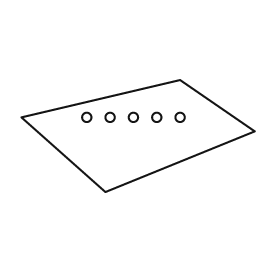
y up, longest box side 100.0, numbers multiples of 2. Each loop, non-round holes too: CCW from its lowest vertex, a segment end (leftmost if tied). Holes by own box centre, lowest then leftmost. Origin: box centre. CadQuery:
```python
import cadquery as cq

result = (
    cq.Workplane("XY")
    .moveTo(-14.0, -24.0)
    .lineTo(50.0, 2.0)
    .lineTo(18.0, 24.0)
    .lineTo(-50.0, 8.0)
    .close()
    .moveTo(-22.0, 8.0)
    .circle(2.0)
    .moveTo(-12.0, 8.0)
    .circle(2.0)
    .moveTo(-2.0, 8.0)
    .circle(2.0)
    .moveTo(8.0, 8.0)
    .circle(2.0)
    .moveTo(18.0, 8.0)
    .circle(2.0)
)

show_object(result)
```